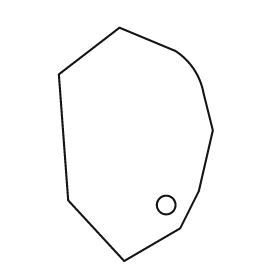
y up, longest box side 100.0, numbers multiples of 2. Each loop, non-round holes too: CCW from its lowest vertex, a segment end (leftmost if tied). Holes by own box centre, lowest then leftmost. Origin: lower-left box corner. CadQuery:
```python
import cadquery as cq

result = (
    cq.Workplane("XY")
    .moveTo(28.0, 0.0)
    .lineTo(52.0, 14.0)
    .lineTo(60.0, 30.0)
    .lineTo(66.0, 56.0)
    .lineTo(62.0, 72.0)
    .threePointArc((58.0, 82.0), (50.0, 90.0))
    .lineTo(26.0, 100.0)
    .lineTo(0.0, 80.0)
    .lineTo(4.0, 26.0)
    .close()
    .moveTo(46.0, 24.0)
    .circle(4.0)
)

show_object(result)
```